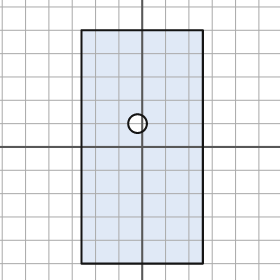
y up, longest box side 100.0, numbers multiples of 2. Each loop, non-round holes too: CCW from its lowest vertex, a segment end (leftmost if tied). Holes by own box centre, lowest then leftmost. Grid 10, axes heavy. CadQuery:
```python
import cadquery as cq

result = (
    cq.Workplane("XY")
    .moveTo(-26.0, -50.0)
    .lineTo(26.0, -50.0)
    .lineTo(26.0, 50.0)
    .lineTo(-26.0, 50.0)
    .close()
    .moveTo(-2.0, 10.0)
    .circle(4.0)
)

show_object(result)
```